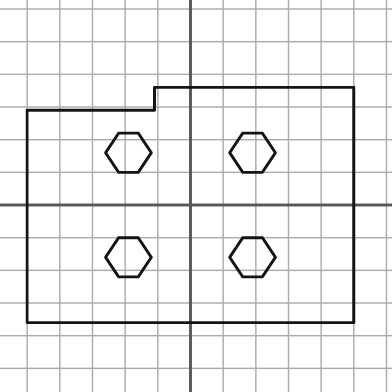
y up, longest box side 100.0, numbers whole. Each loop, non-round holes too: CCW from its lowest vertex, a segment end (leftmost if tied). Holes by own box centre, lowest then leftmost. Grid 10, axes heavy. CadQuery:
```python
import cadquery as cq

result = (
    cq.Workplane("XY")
    .moveTo(-50.0, -36.0)
    .lineTo(50.0, -36.0)
    .lineTo(50.0, 36.0)
    .lineTo(-11.0, 36.0)
    .lineTo(-11.0, 29.0)
    .lineTo(-50.0, 29.0)
    .close()
    .moveTo(-22.0, -22.0)
    .lineTo(-16.0, -22.0)
    .lineTo(-12.0, -16.0)
    .lineTo(-16.0, -10.0)
    .lineTo(-22.0, -10.0)
    .lineTo(-26.0, -16.0)
    .close()
    .moveTo(16.0, -22.0)
    .lineTo(22.0, -22.0)
    .lineTo(26.0, -16.0)
    .lineTo(22.0, -10.0)
    .lineTo(16.0, -10.0)
    .lineTo(12.0, -16.0)
    .close()
    .moveTo(-22.0, 10.0)
    .lineTo(-16.0, 10.0)
    .lineTo(-12.0, 16.0)
    .lineTo(-16.0, 22.0)
    .lineTo(-22.0, 22.0)
    .lineTo(-26.0, 16.0)
    .close()
    .moveTo(16.0, 10.0)
    .lineTo(22.0, 10.0)
    .lineTo(26.0, 16.0)
    .lineTo(22.0, 22.0)
    .lineTo(16.0, 22.0)
    .lineTo(12.0, 16.0)
    .close()
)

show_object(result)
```